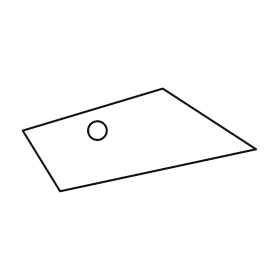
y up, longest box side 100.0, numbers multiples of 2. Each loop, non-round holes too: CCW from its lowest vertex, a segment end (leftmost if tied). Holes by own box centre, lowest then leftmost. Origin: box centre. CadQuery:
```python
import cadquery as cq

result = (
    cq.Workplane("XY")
    .moveTo(-34.0, -22.0)
    .lineTo(50.0, -4.0)
    .lineTo(10.0, 22.0)
    .lineTo(-50.0, 4.0)
    .close()
    .moveTo(-18.0, 4.0)
    .circle(4.0)
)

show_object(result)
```